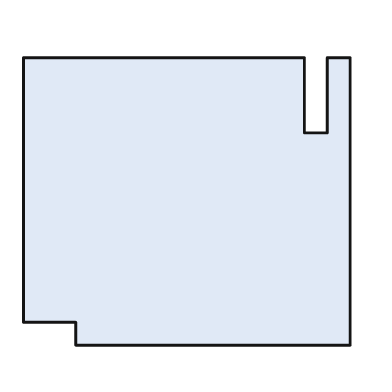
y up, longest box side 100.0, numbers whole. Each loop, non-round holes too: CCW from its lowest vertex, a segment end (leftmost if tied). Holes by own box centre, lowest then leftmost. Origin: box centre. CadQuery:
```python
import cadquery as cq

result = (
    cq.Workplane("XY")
    .moveTo(-34.0, -44.0)
    .lineTo(50.0, -44.0)
    .lineTo(50.0, 44.0)
    .lineTo(43.0, 44.0)
    .lineTo(43.0, 21.0)
    .lineTo(36.0, 21.0)
    .lineTo(36.0, 44.0)
    .lineTo(-50.0, 44.0)
    .lineTo(-50.0, -37.0)
    .lineTo(-34.0, -37.0)
    .close()
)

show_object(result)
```